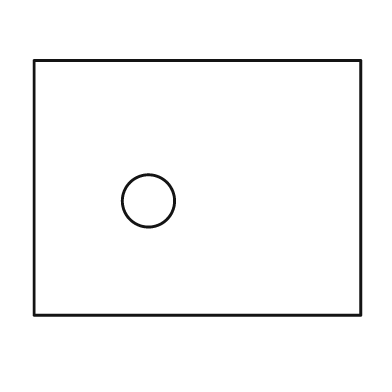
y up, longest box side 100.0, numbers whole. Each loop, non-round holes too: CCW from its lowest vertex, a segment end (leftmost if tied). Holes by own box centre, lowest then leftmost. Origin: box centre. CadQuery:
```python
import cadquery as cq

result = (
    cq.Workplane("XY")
    .moveTo(-50.0, -39.0)
    .lineTo(50.0, -39.0)
    .lineTo(50.0, 39.0)
    .lineTo(-50.0, 39.0)
    .close()
    .moveTo(-15.0, -4.0)
    .circle(8.0)
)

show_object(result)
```